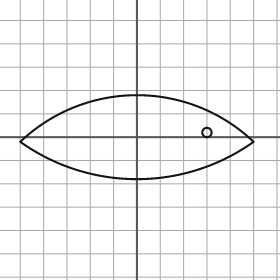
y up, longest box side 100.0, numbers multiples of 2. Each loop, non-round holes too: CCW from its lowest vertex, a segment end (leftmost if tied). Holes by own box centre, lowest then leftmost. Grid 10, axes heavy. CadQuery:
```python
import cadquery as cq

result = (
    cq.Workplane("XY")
    .moveTo(-50.0, -2.0)
    .threePointArc((0.0, -18.0), (50.0, -2.0))
    .threePointArc((0.0, 18.0), (-50.0, -2.0))
    .close()
    .moveTo(30.0, 2.0)
    .circle(2.0)
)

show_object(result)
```